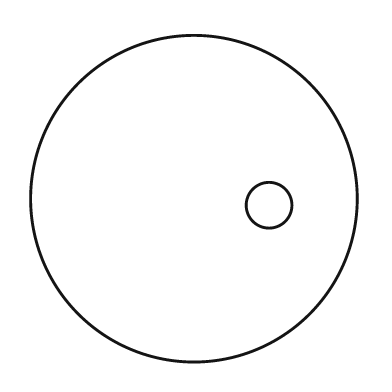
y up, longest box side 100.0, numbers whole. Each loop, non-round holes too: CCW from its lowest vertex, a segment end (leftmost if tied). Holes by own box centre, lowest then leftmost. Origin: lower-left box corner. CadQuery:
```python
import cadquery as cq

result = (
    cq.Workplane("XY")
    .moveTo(50.0, 50.0)
    .circle(50.0)
    .moveTo(73.0, 48.0)
    .circle(7.0)
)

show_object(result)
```